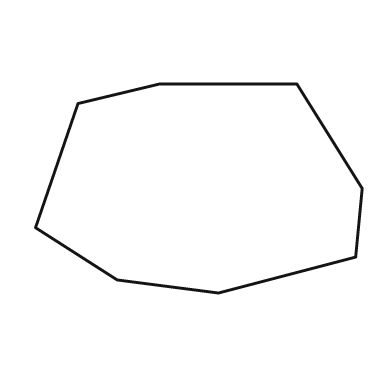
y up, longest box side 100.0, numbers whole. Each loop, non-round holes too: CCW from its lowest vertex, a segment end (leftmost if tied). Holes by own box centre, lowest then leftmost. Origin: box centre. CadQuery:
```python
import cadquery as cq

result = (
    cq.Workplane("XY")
    .moveTo(6.0, -32.0)
    .lineTo(48.0, -21.0)
    .lineTo(50.0, 0.0)
    .lineTo(30.0, 32.0)
    .lineTo(-12.0, 32.0)
    .lineTo(-37.0, 26.0)
    .lineTo(-50.0, -12.0)
    .lineTo(-25.0, -28.0)
    .close()
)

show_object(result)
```